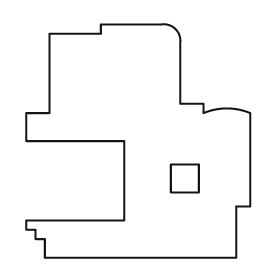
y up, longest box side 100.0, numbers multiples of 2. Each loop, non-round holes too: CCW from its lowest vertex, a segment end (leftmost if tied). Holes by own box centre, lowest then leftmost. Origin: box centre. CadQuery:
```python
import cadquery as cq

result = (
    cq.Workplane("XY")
    .moveTo(-40.0, -50.0)
    .lineTo(42.0, -50.0)
    .lineTo(42.0, -28.0)
    .lineTo(48.0, -28.0)
    .lineTo(48.0, 12.0)
    .threePointArc((38.0, 14.0), (28.0, 12.0))
    .lineTo(28.0, 16.0)
    .lineTo(18.0, 16.0)
    .lineTo(18.0, 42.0)
    .threePointArc((16.0, 48.0), (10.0, 50.0))
    .lineTo(-16.0, 50.0)
    .lineTo(-16.0, 46.0)
    .lineTo(-38.0, 46.0)
    .lineTo(-38.0, 12.0)
    .lineTo(-48.0, 12.0)
    .lineTo(-48.0, 0.0)
    .lineTo(-6.0, 0.0)
    .lineTo(-6.0, -34.0)
    .lineTo(-48.0, -34.0)
    .lineTo(-48.0, -38.0)
    .lineTo(-44.0, -38.0)
    .lineTo(-44.0, -42.0)
    .lineTo(-40.0, -42.0)
    .close()
    .moveTo(14.0, -22.0)
    .lineTo(26.0, -22.0)
    .lineTo(26.0, -10.0)
    .lineTo(14.0, -10.0)
    .close()
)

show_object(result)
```